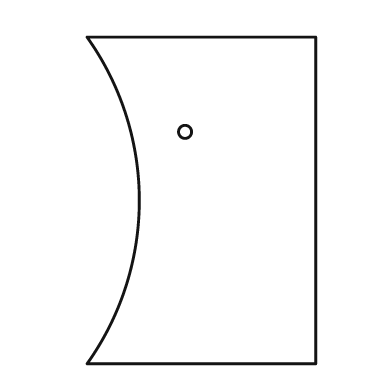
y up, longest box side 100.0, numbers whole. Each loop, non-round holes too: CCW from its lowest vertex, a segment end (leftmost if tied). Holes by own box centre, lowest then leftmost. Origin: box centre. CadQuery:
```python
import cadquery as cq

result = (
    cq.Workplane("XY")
    .moveTo(-35.0, -50.0)
    .lineTo(35.0, -50.0)
    .lineTo(35.0, 50.0)
    .lineTo(-35.0, 50.0)
    .threePointArc((-19.0, 0.0), (-35.0, -50.0))
    .close()
    .moveTo(-5.0, 21.0)
    .circle(2.0)
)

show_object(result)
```